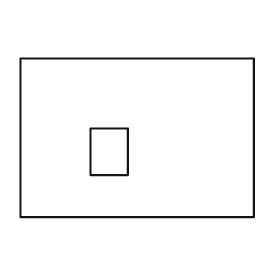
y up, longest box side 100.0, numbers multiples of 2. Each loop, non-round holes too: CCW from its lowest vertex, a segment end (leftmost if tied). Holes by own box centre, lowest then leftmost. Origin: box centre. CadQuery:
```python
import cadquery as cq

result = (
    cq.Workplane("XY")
    .moveTo(-50.0, -34.0)
    .lineTo(50.0, -34.0)
    .lineTo(50.0, 34.0)
    .lineTo(-50.0, 34.0)
    .close()
    .moveTo(-20.0, -16.0)
    .lineTo(-4.0, -16.0)
    .lineTo(-4.0, 4.0)
    .lineTo(-20.0, 4.0)
    .close()
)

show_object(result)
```